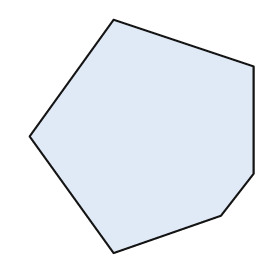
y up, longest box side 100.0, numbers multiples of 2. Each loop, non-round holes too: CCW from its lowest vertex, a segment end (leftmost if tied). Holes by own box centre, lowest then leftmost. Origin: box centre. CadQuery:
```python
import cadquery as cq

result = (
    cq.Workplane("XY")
    .moveTo(-12.0, -50.0)
    .lineTo(34.0, -34.0)
    .lineTo(48.0, -16.0)
    .lineTo(48.0, 30.0)
    .lineTo(-12.0, 50.0)
    .lineTo(-48.0, 0.0)
    .close()
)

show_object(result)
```